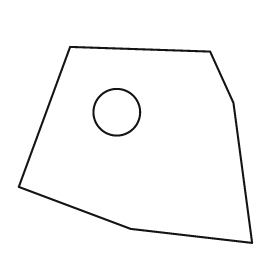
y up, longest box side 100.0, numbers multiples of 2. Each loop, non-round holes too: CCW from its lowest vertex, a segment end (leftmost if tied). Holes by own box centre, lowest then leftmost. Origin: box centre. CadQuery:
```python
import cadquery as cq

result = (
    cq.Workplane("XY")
    .moveTo(50.0, -42.0)
    .lineTo(42.0, 18.0)
    .lineTo(32.0, 40.0)
    .lineTo(-28.0, 42.0)
    .lineTo(-50.0, -18.0)
    .lineTo(-2.0, -36.0)
    .close()
    .moveTo(-8.0, 14.0)
    .circle(10.0)
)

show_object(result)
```